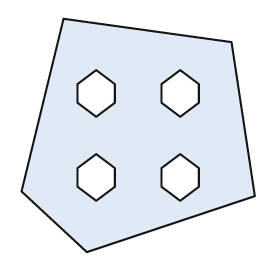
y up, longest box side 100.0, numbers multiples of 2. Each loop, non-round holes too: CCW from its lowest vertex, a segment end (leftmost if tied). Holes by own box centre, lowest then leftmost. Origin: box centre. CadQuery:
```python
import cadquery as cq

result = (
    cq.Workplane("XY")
    .moveTo(-22.0, -50.0)
    .lineTo(50.0, -26.0)
    .lineTo(40.0, 40.0)
    .lineTo(-32.0, 50.0)
    .lineTo(-50.0, -24.0)
    .close()
    .moveTo(-18.0, -28.0)
    .lineTo(-10.0, -22.0)
    .lineTo(-10.0, -14.0)
    .lineTo(-18.0, -8.0)
    .lineTo(-26.0, -14.0)
    .lineTo(-26.0, -22.0)
    .close()
    .moveTo(18.0, -28.0)
    .lineTo(26.0, -22.0)
    .lineTo(26.0, -14.0)
    .lineTo(18.0, -8.0)
    .lineTo(10.0, -14.0)
    .lineTo(10.0, -22.0)
    .close()
    .moveTo(-18.0, 8.0)
    .lineTo(-10.0, 14.0)
    .lineTo(-10.0, 22.0)
    .lineTo(-18.0, 28.0)
    .lineTo(-26.0, 22.0)
    .lineTo(-26.0, 14.0)
    .close()
    .moveTo(18.0, 8.0)
    .lineTo(26.0, 14.0)
    .lineTo(26.0, 22.0)
    .lineTo(18.0, 28.0)
    .lineTo(10.0, 22.0)
    .lineTo(10.0, 14.0)
    .close()
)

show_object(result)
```